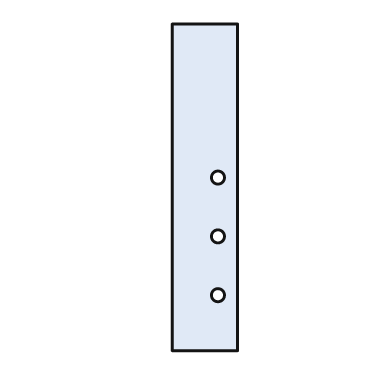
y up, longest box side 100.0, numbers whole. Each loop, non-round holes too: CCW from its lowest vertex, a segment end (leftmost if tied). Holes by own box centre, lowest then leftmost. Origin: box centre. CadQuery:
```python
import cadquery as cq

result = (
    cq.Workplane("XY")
    .moveTo(-10.0, -50.0)
    .lineTo(10.0, -50.0)
    .lineTo(10.0, 50.0)
    .lineTo(-10.0, 50.0)
    .close()
    .moveTo(4.0, -33.0)
    .circle(2.0)
    .moveTo(4.0, -15.0)
    .circle(2.0)
    .moveTo(4.0, 3.0)
    .circle(2.0)
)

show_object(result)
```